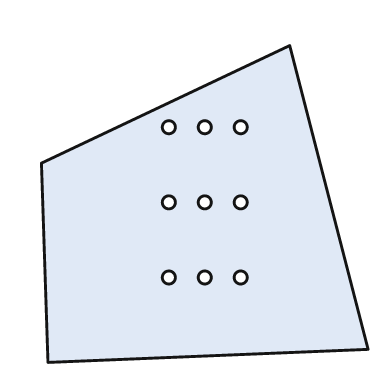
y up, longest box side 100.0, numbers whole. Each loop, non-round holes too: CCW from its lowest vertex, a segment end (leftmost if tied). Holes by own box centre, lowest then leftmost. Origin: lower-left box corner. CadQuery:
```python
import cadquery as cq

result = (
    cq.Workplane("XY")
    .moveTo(2.0, 0.0)
    .lineTo(100.0, 4.0)
    .lineTo(76.0, 97.0)
    .lineTo(0.0, 61.0)
    .close()
    .moveTo(39.0, 26.0)
    .circle(2.0)
    .moveTo(50.0, 26.0)
    .circle(2.0)
    .moveTo(61.0, 26.0)
    .circle(2.0)
    .moveTo(39.0, 49.0)
    .circle(2.0)
    .moveTo(50.0, 49.0)
    .circle(2.0)
    .moveTo(61.0, 49.0)
    .circle(2.0)
    .moveTo(39.0, 72.0)
    .circle(2.0)
    .moveTo(50.0, 72.0)
    .circle(2.0)
    .moveTo(61.0, 72.0)
    .circle(2.0)
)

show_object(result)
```